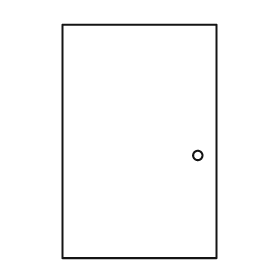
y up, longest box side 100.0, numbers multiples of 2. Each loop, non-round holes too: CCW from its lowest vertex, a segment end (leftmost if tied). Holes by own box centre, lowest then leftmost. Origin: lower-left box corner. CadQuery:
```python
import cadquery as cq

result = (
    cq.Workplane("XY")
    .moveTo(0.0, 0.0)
    .lineTo(66.0, 0.0)
    .lineTo(66.0, 100.0)
    .lineTo(0.0, 100.0)
    .close()
    .moveTo(58.0, 44.0)
    .circle(2.0)
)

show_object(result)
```